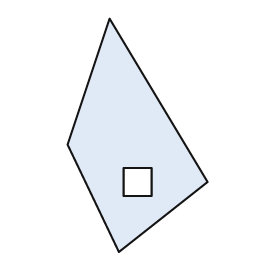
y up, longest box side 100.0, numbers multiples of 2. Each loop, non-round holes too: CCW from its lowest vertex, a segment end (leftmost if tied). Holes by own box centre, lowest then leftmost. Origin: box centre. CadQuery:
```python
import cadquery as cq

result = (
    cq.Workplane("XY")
    .moveTo(-8.0, -50.0)
    .lineTo(30.0, -20.0)
    .lineTo(-12.0, 50.0)
    .lineTo(-30.0, -4.0)
    .close()
    .moveTo(-6.0, -26.0)
    .lineTo(6.0, -26.0)
    .lineTo(6.0, -14.0)
    .lineTo(-6.0, -14.0)
    .close()
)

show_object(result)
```